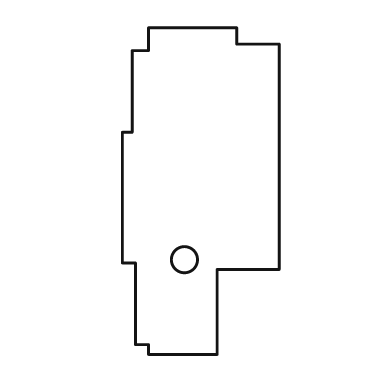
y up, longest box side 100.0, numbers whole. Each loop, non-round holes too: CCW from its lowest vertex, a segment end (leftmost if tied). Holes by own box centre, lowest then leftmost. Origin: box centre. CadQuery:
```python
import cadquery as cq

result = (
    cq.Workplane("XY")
    .moveTo(-16.0, -50.0)
    .lineTo(5.0, -50.0)
    .lineTo(5.0, -24.0)
    .lineTo(24.0, -24.0)
    .lineTo(24.0, 45.0)
    .lineTo(11.0, 45.0)
    .lineTo(11.0, 50.0)
    .lineTo(-16.0, 50.0)
    .lineTo(-16.0, 43.0)
    .lineTo(-21.0, 43.0)
    .lineTo(-21.0, 18.0)
    .lineTo(-24.0, 18.0)
    .lineTo(-24.0, -22.0)
    .lineTo(-20.0, -22.0)
    .lineTo(-20.0, -47.0)
    .lineTo(-16.0, -47.0)
    .close()
    .moveTo(-5.0, -21.0)
    .circle(4.0)
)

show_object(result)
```